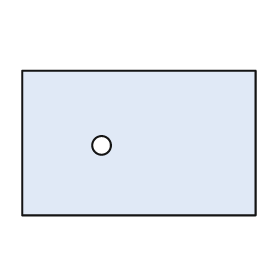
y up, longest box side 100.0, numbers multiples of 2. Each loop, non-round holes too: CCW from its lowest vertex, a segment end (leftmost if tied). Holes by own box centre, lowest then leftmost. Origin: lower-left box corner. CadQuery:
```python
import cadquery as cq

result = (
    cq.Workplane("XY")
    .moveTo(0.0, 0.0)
    .lineTo(100.0, 0.0)
    .lineTo(100.0, 62.0)
    .lineTo(0.0, 62.0)
    .close()
    .moveTo(34.0, 30.0)
    .circle(4.0)
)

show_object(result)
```